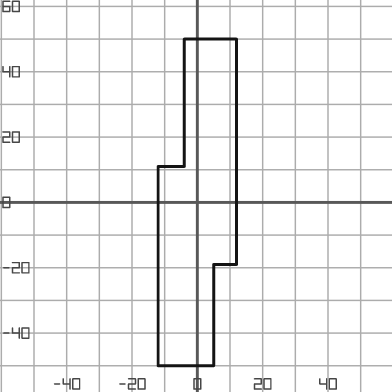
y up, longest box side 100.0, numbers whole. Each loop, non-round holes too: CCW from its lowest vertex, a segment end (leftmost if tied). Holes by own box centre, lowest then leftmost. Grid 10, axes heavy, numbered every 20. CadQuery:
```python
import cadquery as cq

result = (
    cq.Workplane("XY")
    .moveTo(-12.0, -50.0)
    .lineTo(5.0, -50.0)
    .lineTo(5.0, -19.0)
    .lineTo(12.0, -19.0)
    .lineTo(12.0, 50.0)
    .lineTo(-4.0, 50.0)
    .lineTo(-4.0, 11.0)
    .lineTo(-12.0, 11.0)
    .close()
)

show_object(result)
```